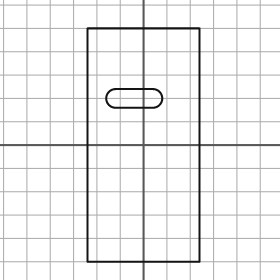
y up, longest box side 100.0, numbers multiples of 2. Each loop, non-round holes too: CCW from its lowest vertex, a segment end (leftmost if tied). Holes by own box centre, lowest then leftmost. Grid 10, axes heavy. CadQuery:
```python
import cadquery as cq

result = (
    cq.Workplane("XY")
    .moveTo(-24.0, -50.0)
    .lineTo(24.0, -50.0)
    .lineTo(24.0, 50.0)
    .lineTo(-24.0, 50.0)
    .close()
    .moveTo(-12.0, 16.0)
    .lineTo(4.0, 16.0)
    .threePointArc((8.0, 20.0), (4.0, 24.0))
    .lineTo(-12.0, 24.0)
    .threePointArc((-16.0, 20.0), (-12.0, 16.0))
    .close()
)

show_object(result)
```